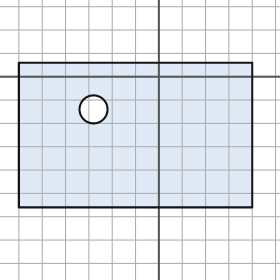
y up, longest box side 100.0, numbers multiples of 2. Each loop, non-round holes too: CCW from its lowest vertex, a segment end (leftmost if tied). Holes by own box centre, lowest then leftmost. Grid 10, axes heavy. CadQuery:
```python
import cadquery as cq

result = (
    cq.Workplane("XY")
    .moveTo(-60.0, -56.0)
    .lineTo(40.0, -56.0)
    .lineTo(40.0, 6.0)
    .lineTo(-60.0, 6.0)
    .close()
    .moveTo(-28.0, -14.0)
    .circle(6.0)
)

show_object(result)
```